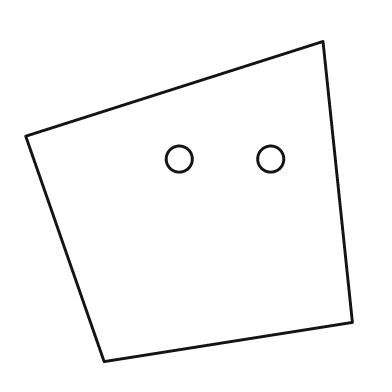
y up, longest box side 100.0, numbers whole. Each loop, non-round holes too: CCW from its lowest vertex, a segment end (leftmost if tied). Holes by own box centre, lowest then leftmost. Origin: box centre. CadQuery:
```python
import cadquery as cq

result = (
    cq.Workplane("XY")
    .moveTo(-26.0, -49.0)
    .lineTo(50.0, -37.0)
    .lineTo(41.0, 49.0)
    .lineTo(-50.0, 20.0)
    .close()
    .moveTo(-3.0, 13.0)
    .circle(4.0)
    .moveTo(25.0, 13.0)
    .circle(4.0)
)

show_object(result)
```